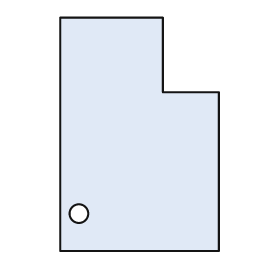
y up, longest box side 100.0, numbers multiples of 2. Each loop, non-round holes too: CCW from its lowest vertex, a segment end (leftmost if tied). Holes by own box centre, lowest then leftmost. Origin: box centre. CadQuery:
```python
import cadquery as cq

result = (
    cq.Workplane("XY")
    .moveTo(-34.0, -50.0)
    .lineTo(34.0, -50.0)
    .lineTo(34.0, 18.0)
    .lineTo(10.0, 18.0)
    .lineTo(10.0, 50.0)
    .lineTo(-34.0, 50.0)
    .close()
    .moveTo(-26.0, -34.0)
    .circle(4.0)
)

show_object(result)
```